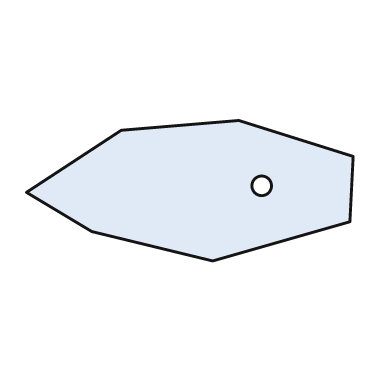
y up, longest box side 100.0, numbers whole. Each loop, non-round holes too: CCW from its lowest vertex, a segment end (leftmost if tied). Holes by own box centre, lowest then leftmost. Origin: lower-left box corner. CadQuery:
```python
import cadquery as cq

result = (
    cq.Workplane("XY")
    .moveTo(57.0, 0.0)
    .lineTo(99.0, 12.0)
    .lineTo(100.0, 32.0)
    .lineTo(65.0, 43.0)
    .lineTo(29.0, 40.0)
    .lineTo(0.0, 21.0)
    .lineTo(20.0, 9.0)
    .close()
    .moveTo(72.0, 23.0)
    .circle(3.0)
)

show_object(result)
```